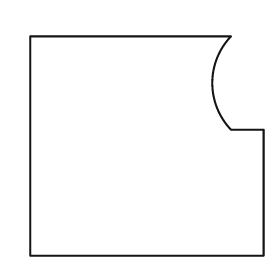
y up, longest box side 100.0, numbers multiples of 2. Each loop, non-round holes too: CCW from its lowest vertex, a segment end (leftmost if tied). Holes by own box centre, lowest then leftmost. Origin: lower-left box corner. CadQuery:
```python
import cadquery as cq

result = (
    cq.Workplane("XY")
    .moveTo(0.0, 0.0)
    .lineTo(100.0, 0.0)
    .lineTo(100.0, 54.0)
    .lineTo(86.0, 54.0)
    .threePointArc((78.0, 74.0), (86.0, 94.0))
    .lineTo(0.0, 94.0)
    .close()
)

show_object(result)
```